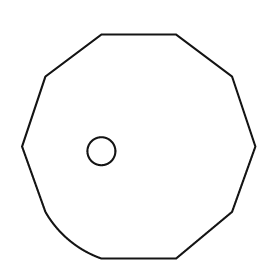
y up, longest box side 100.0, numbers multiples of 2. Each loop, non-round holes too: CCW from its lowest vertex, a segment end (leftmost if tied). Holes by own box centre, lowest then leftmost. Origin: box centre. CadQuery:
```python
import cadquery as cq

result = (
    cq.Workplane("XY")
    .moveTo(-16.0, -48.0)
    .lineTo(16.0, -48.0)
    .lineTo(40.0, -28.0)
    .lineTo(50.0, 0.0)
    .lineTo(40.0, 30.0)
    .lineTo(16.0, 48.0)
    .lineTo(-16.0, 48.0)
    .lineTo(-40.0, 30.0)
    .lineTo(-50.0, 0.0)
    .lineTo(-40.0, -28.0)
    .threePointArc((-30.0, -40.0), (-16.0, -48.0))
    .close()
    .moveTo(-16.0, -2.0)
    .circle(6.0)
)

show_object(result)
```